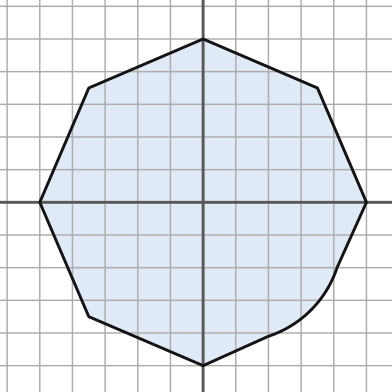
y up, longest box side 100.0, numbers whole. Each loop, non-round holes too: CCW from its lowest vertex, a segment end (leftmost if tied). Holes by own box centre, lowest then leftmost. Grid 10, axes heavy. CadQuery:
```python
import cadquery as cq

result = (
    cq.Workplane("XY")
    .moveTo(0.0, -50.0)
    .lineTo(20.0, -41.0)
    .threePointArc((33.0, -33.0), (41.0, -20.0))
    .lineTo(50.0, 0.0)
    .lineTo(35.0, 35.0)
    .lineTo(0.0, 50.0)
    .lineTo(-35.0, 35.0)
    .lineTo(-50.0, 0.0)
    .lineTo(-35.0, -35.0)
    .close()
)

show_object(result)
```